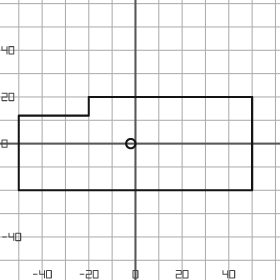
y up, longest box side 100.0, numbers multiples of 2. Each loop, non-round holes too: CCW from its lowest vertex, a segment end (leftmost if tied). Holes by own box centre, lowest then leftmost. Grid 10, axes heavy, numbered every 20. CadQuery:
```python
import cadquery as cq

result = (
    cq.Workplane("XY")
    .moveTo(-50.0, -20.0)
    .lineTo(50.0, -20.0)
    .lineTo(50.0, 20.0)
    .lineTo(-20.0, 20.0)
    .lineTo(-20.0, 12.0)
    .lineTo(-50.0, 12.0)
    .close()
    .moveTo(-2.0, 0.0)
    .circle(2.0)
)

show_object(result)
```